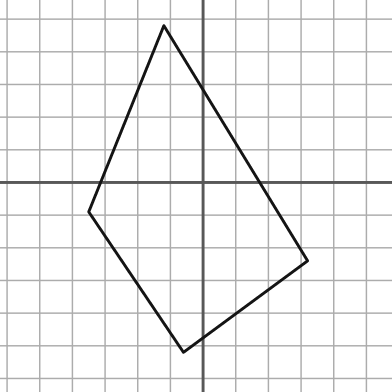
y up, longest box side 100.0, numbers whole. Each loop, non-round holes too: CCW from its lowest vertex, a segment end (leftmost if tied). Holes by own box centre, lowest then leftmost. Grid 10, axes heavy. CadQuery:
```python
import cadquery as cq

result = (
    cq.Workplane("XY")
    .moveTo(-6.0, -52.0)
    .lineTo(32.0, -24.0)
    .lineTo(-12.0, 48.0)
    .lineTo(-35.0, -9.0)
    .close()
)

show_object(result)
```